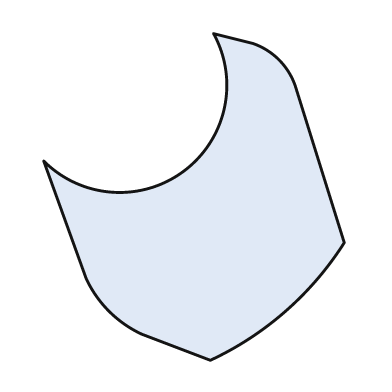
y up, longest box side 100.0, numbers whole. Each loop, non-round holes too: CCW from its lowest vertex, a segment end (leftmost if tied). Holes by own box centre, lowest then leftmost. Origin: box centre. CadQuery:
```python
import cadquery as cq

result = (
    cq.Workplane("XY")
    .moveTo(5.0, -50.0)
    .threePointArc((28.0, -35.0), (46.0, -14.0))
    .lineTo(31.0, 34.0)
    .threePointArc((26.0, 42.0), (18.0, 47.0))
    .lineTo(6.0, 50.0)
    .threePointArc((-3.0, 8.0), (-46.0, 11.0))
    .lineTo(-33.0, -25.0)
    .threePointArc((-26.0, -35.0), (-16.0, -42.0))
    .close()
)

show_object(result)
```